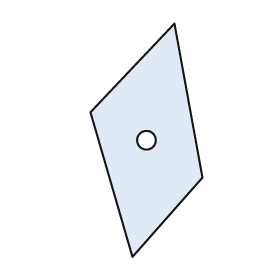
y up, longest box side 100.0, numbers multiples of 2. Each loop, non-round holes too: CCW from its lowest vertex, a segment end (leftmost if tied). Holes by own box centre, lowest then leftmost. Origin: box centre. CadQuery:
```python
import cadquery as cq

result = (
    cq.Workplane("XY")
    .moveTo(-6.0, -50.0)
    .lineTo(24.0, -16.0)
    .lineTo(12.0, 50.0)
    .lineTo(-24.0, 12.0)
    .close()
    .moveTo(0.0, 0.0)
    .circle(4.0)
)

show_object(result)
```